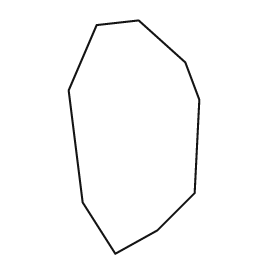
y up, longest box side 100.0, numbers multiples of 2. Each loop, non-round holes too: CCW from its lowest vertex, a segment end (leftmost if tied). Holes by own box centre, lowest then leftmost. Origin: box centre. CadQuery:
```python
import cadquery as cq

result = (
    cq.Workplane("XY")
    .moveTo(-8.0, -50.0)
    .lineTo(10.0, -40.0)
    .lineTo(26.0, -24.0)
    .lineTo(28.0, 16.0)
    .lineTo(22.0, 32.0)
    .lineTo(2.0, 50.0)
    .lineTo(-16.0, 48.0)
    .lineTo(-28.0, 20.0)
    .lineTo(-22.0, -28.0)
    .close()
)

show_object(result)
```